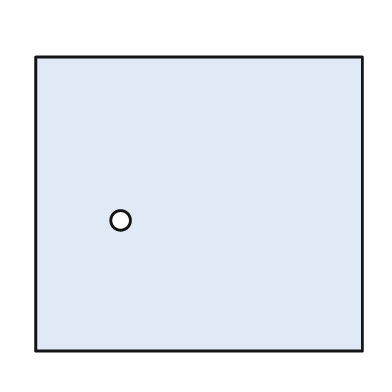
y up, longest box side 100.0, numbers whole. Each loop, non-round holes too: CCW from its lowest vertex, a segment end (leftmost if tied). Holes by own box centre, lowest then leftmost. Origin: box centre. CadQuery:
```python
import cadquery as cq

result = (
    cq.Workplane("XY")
    .moveTo(-50.0, -45.0)
    .lineTo(50.0, -45.0)
    .lineTo(50.0, 45.0)
    .lineTo(-50.0, 45.0)
    .close()
    .moveTo(-24.0, -5.0)
    .circle(3.0)
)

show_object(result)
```